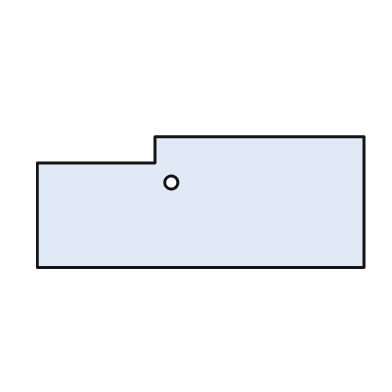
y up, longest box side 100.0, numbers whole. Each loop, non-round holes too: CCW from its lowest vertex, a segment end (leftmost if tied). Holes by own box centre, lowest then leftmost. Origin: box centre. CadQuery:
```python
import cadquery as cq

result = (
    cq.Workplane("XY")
    .moveTo(-50.0, -20.0)
    .lineTo(50.0, -20.0)
    .lineTo(50.0, 20.0)
    .lineTo(-14.0, 20.0)
    .lineTo(-14.0, 12.0)
    .lineTo(-50.0, 12.0)
    .close()
    .moveTo(-9.0, 6.0)
    .circle(2.0)
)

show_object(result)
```